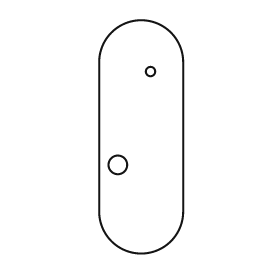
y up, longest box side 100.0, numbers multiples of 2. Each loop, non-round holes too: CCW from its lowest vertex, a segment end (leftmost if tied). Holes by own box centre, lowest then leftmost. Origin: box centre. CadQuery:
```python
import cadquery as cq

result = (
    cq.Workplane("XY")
    .moveTo(-18.0, -32.0)
    .threePointArc((0.0, -50.0), (18.0, -32.0))
    .lineTo(18.0, 32.0)
    .threePointArc((0.0, 50.0), (-18.0, 32.0))
    .close()
    .moveTo(-10.0, -12.0)
    .circle(4.0)
    .moveTo(4.0, 28.0)
    .circle(2.0)
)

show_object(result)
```